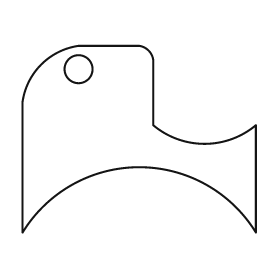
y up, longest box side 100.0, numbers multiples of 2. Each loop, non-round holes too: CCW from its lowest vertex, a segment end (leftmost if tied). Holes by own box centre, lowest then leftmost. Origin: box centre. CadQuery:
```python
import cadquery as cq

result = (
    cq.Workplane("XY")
    .moveTo(-50.0, -40.0)
    .threePointArc((0.0, -12.0), (50.0, -40.0))
    .lineTo(50.0, 6.0)
    .threePointArc((28.0, -2.0), (6.0, 6.0))
    .lineTo(6.0, 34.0)
    .threePointArc((4.0, 38.0), (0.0, 40.0))
    .lineTo(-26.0, 40.0)
    .threePointArc((-42.0, 32.0), (-50.0, 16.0))
    .close()
    .moveTo(-26.0, 30.0)
    .circle(6.0)
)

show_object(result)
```